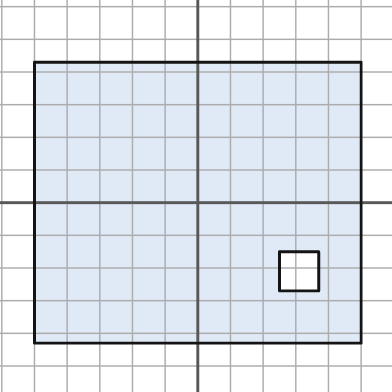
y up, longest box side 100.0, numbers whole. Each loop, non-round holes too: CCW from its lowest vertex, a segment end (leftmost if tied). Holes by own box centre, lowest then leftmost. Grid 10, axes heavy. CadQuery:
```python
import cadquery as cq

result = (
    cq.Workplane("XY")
    .moveTo(-50.0, -43.0)
    .lineTo(50.0, -43.0)
    .lineTo(50.0, 43.0)
    .lineTo(-50.0, 43.0)
    .close()
    .moveTo(25.0, -27.0)
    .lineTo(37.0, -27.0)
    .lineTo(37.0, -15.0)
    .lineTo(25.0, -15.0)
    .close()
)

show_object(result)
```